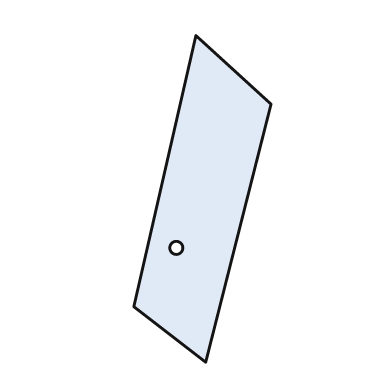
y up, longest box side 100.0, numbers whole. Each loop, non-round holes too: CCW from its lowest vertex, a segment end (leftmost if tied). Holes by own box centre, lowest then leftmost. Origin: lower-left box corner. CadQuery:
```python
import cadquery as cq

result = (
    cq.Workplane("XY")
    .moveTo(22.0, 0.0)
    .lineTo(42.0, 79.0)
    .lineTo(19.0, 100.0)
    .lineTo(0.0, 17.0)
    .close()
    .moveTo(13.0, 35.0)
    .circle(2.0)
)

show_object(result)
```